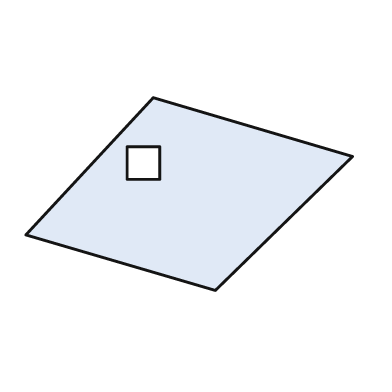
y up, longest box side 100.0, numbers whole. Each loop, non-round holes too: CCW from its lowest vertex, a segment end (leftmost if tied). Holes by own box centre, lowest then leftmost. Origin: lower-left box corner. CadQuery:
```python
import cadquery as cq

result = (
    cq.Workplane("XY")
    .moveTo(58.0, 0.0)
    .lineTo(100.0, 41.0)
    .lineTo(39.0, 59.0)
    .lineTo(0.0, 17.0)
    .close()
    .moveTo(31.0, 34.0)
    .lineTo(41.0, 34.0)
    .lineTo(41.0, 44.0)
    .lineTo(31.0, 44.0)
    .close()
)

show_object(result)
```